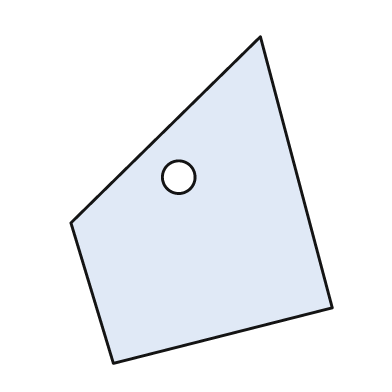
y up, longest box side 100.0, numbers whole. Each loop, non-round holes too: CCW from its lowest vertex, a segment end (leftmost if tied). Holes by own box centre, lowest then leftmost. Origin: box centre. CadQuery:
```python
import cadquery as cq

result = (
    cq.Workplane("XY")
    .moveTo(-27.0, -50.0)
    .lineTo(40.0, -33.0)
    .lineTo(18.0, 50.0)
    .lineTo(-40.0, -7.0)
    .close()
    .moveTo(-7.0, 7.0)
    .circle(5.0)
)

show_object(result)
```